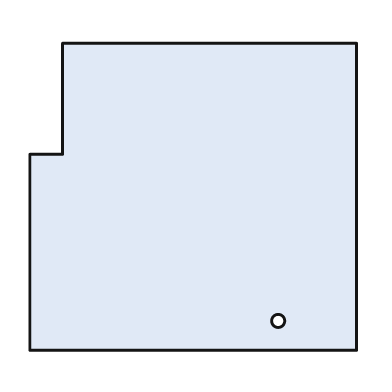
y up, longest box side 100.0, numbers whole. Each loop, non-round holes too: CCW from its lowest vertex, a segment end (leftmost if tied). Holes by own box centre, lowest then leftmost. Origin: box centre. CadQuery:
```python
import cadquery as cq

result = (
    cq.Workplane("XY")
    .moveTo(-50.0, -47.0)
    .lineTo(50.0, -47.0)
    .lineTo(50.0, 47.0)
    .lineTo(-40.0, 47.0)
    .lineTo(-40.0, 13.0)
    .lineTo(-50.0, 13.0)
    .close()
    .moveTo(26.0, -38.0)
    .circle(2.0)
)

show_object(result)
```